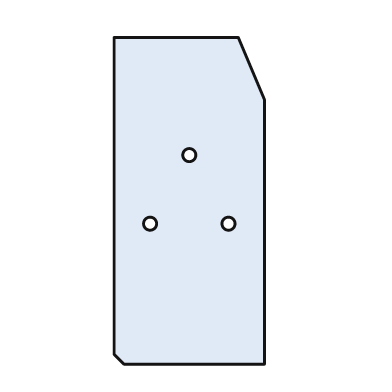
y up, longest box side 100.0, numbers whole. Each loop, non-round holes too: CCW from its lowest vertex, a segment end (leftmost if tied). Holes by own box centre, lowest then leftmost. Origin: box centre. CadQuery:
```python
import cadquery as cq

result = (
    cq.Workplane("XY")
    .moveTo(-20.0, -50.0)
    .lineTo(23.0, -50.0)
    .lineTo(23.0, 31.0)
    .lineTo(15.0, 50.0)
    .lineTo(-23.0, 50.0)
    .lineTo(-23.0, -47.0)
    .close()
    .moveTo(-12.0, -7.0)
    .circle(2.0)
    .moveTo(12.0, -7.0)
    .circle(2.0)
    .moveTo(0.0, 14.0)
    .circle(2.0)
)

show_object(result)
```